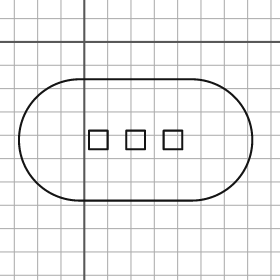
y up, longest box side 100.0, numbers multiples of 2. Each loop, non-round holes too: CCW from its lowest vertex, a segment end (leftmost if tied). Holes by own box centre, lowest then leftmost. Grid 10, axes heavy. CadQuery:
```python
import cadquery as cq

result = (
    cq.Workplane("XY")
    .moveTo(-2.0, -68.0)
    .lineTo(46.0, -68.0)
    .threePointArc((72.0, -42.0), (46.0, -16.0))
    .lineTo(-2.0, -16.0)
    .threePointArc((-28.0, -42.0), (-2.0, -68.0))
    .close()
    .moveTo(2.0, -46.0)
    .lineTo(10.0, -46.0)
    .lineTo(10.0, -38.0)
    .lineTo(2.0, -38.0)
    .close()
    .moveTo(18.0, -46.0)
    .lineTo(26.0, -46.0)
    .lineTo(26.0, -38.0)
    .lineTo(18.0, -38.0)
    .close()
    .moveTo(34.0, -46.0)
    .lineTo(42.0, -46.0)
    .lineTo(42.0, -38.0)
    .lineTo(34.0, -38.0)
    .close()
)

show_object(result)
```